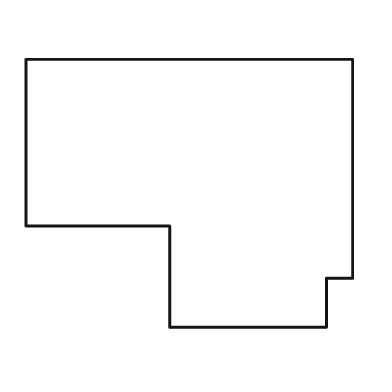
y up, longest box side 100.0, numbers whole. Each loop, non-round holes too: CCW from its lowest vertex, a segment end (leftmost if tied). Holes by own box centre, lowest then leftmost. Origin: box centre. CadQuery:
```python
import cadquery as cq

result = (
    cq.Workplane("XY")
    .moveTo(-6.0, -41.0)
    .lineTo(42.0, -41.0)
    .lineTo(42.0, -26.0)
    .lineTo(50.0, -26.0)
    .lineTo(50.0, 41.0)
    .lineTo(-50.0, 41.0)
    .lineTo(-50.0, -10.0)
    .lineTo(-6.0, -10.0)
    .close()
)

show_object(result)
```